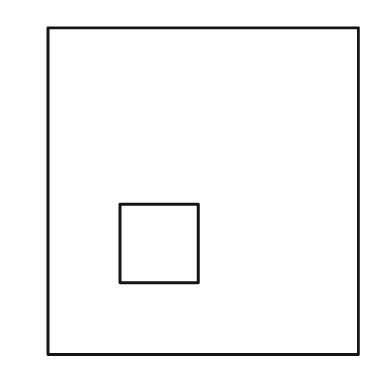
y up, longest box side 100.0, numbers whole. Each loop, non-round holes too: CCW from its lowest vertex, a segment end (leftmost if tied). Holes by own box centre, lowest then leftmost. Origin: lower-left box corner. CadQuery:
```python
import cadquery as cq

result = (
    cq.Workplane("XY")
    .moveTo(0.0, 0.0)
    .lineTo(95.0, 0.0)
    .lineTo(95.0, 100.0)
    .lineTo(0.0, 100.0)
    .close()
    .moveTo(22.0, 22.0)
    .lineTo(46.0, 22.0)
    .lineTo(46.0, 46.0)
    .lineTo(22.0, 46.0)
    .close()
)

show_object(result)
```